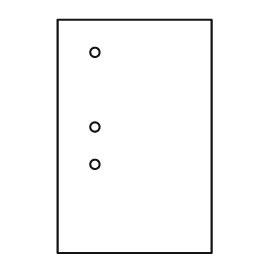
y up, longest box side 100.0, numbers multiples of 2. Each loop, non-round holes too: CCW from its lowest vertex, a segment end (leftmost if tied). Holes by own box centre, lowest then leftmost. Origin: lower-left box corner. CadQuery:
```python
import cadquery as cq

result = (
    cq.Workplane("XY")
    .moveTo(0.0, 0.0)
    .lineTo(66.0, 0.0)
    .lineTo(66.0, 100.0)
    .lineTo(0.0, 100.0)
    .close()
    .moveTo(16.0, 38.0)
    .circle(2.0)
    .moveTo(16.0, 54.0)
    .circle(2.0)
    .moveTo(16.0, 86.0)
    .circle(2.0)
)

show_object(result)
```